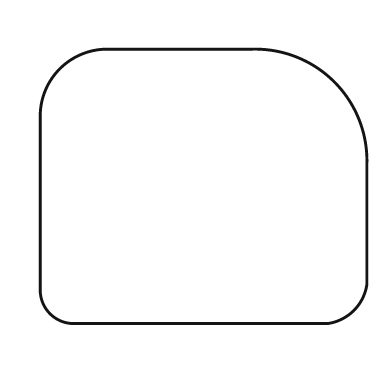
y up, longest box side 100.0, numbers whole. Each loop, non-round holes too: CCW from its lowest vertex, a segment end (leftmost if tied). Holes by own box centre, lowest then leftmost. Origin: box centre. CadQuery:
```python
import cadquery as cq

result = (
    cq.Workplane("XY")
    .moveTo(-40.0, -42.0)
    .lineTo(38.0, -42.0)
    .threePointArc((46.0, -38.0), (50.0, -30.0))
    .lineTo(50.0, 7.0)
    .threePointArc((40.0, 32.0), (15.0, 42.0))
    .lineTo(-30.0, 42.0)
    .threePointArc((-44.0, 36.0), (-50.0, 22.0))
    .lineTo(-50.0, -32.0)
    .threePointArc((-47.0, -39.0), (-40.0, -42.0))
    .close()
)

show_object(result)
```